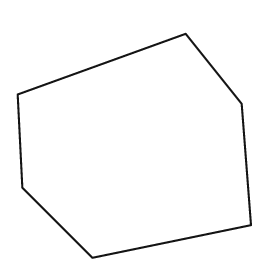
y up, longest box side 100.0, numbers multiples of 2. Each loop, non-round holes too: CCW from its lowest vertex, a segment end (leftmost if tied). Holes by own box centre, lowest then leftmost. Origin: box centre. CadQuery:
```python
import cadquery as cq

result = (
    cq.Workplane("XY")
    .moveTo(-18.0, -48.0)
    .lineTo(50.0, -34.0)
    .lineTo(46.0, 18.0)
    .lineTo(22.0, 48.0)
    .lineTo(-50.0, 22.0)
    .lineTo(-48.0, -18.0)
    .close()
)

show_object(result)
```